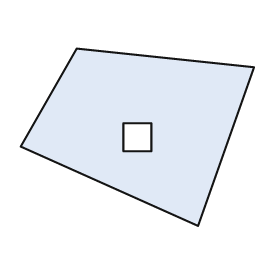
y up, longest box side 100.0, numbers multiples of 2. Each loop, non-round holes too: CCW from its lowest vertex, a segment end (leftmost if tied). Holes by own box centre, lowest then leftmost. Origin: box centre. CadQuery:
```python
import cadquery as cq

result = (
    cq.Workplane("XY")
    .moveTo(26.0, -38.0)
    .lineTo(50.0, 30.0)
    .lineTo(-26.0, 38.0)
    .lineTo(-50.0, -4.0)
    .close()
    .moveTo(-6.0, -6.0)
    .lineTo(6.0, -6.0)
    .lineTo(6.0, 6.0)
    .lineTo(-6.0, 6.0)
    .close()
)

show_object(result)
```